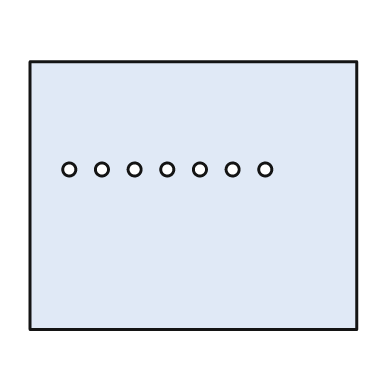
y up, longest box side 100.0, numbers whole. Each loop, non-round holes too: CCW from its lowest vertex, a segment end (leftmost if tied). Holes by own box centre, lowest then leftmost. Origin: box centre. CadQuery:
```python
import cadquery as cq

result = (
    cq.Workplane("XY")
    .moveTo(-50.0, -41.0)
    .lineTo(50.0, -41.0)
    .lineTo(50.0, 41.0)
    .lineTo(-50.0, 41.0)
    .close()
    .moveTo(-38.0, 8.0)
    .circle(2.0)
    .moveTo(-28.0, 8.0)
    .circle(2.0)
    .moveTo(-18.0, 8.0)
    .circle(2.0)
    .moveTo(-8.0, 8.0)
    .circle(2.0)
    .moveTo(2.0, 8.0)
    .circle(2.0)
    .moveTo(12.0, 8.0)
    .circle(2.0)
    .moveTo(22.0, 8.0)
    .circle(2.0)
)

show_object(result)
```